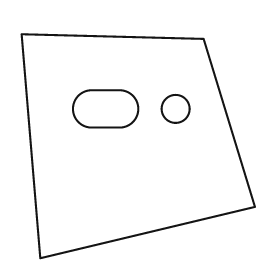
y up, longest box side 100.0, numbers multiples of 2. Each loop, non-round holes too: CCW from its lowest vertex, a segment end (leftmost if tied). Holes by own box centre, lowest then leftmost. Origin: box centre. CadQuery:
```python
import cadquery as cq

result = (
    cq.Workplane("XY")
    .moveTo(-42.0, -48.0)
    .lineTo(50.0, -26.0)
    .lineTo(28.0, 46.0)
    .lineTo(-50.0, 48.0)
    .close()
    .moveTo(-20.0, 8.0)
    .lineTo(-8.0, 8.0)
    .threePointArc((0.0, 16.0), (-8.0, 24.0))
    .lineTo(-20.0, 24.0)
    .threePointArc((-28.0, 16.0), (-20.0, 8.0))
    .close()
    .moveTo(16.0, 16.0)
    .circle(6.0)
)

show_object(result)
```